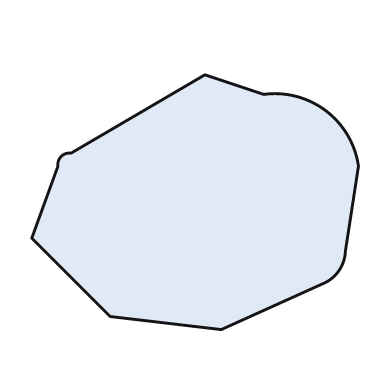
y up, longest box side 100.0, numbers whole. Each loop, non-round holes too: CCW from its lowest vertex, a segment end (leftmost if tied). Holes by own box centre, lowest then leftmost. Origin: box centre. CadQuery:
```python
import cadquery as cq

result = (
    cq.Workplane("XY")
    .moveTo(8.0, -39.0)
    .lineTo(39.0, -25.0)
    .threePointArc((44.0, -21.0), (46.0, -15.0))
    .lineTo(50.0, 11.0)
    .threePointArc((40.0, 28.0), (21.0, 33.0))
    .lineTo(3.0, 39.0)
    .lineTo(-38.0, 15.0)
    .threePointArc((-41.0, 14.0), (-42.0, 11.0))
    .lineTo(-50.0, -11.0)
    .lineTo(-26.0, -35.0)
    .close()
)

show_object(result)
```